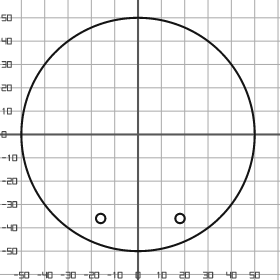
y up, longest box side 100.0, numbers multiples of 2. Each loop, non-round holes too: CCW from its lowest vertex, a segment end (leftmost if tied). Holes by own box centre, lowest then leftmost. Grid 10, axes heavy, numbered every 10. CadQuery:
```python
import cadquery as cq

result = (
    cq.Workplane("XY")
    .moveTo(0.0, 0.0)
    .circle(50.0)
    .moveTo(-16.0, -36.0)
    .circle(2.0)
    .moveTo(18.0, -36.0)
    .circle(2.0)
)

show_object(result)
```